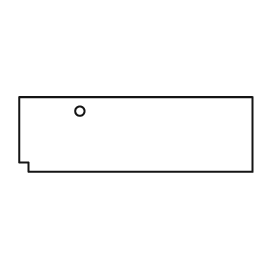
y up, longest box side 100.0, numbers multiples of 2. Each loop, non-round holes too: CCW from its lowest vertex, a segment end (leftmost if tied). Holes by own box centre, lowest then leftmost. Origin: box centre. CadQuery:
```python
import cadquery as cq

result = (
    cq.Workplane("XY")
    .moveTo(-46.0, -16.0)
    .lineTo(50.0, -16.0)
    .lineTo(50.0, 16.0)
    .lineTo(-50.0, 16.0)
    .lineTo(-50.0, -12.0)
    .lineTo(-46.0, -12.0)
    .close()
    .moveTo(-24.0, 10.0)
    .circle(2.0)
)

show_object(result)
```